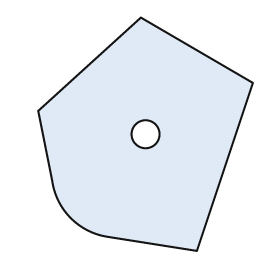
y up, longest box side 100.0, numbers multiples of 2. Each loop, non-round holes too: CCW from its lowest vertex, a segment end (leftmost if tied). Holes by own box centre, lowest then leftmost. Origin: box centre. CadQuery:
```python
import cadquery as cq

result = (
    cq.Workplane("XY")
    .moveTo(22.0, -50.0)
    .lineTo(46.0, 22.0)
    .lineTo(-2.0, 50.0)
    .lineTo(-46.0, 10.0)
    .lineTo(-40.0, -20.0)
    .threePointArc((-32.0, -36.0), (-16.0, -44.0))
    .close()
    .moveTo(0.0, 0.0)
    .circle(6.0)
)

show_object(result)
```